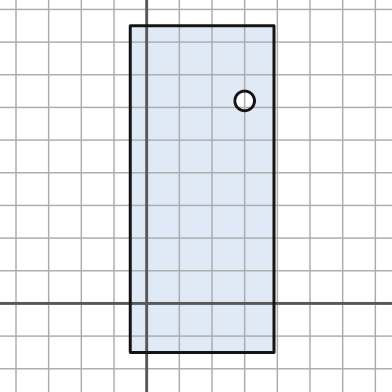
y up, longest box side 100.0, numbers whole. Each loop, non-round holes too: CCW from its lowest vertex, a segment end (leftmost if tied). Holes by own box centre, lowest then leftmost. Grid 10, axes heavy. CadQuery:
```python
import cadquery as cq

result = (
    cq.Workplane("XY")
    .moveTo(-5.0, -15.0)
    .lineTo(39.0, -15.0)
    .lineTo(39.0, 85.0)
    .lineTo(-5.0, 85.0)
    .close()
    .moveTo(30.0, 62.0)
    .circle(3.0)
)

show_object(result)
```